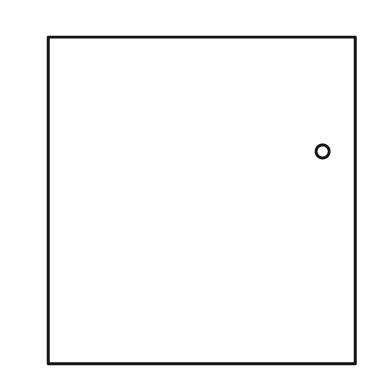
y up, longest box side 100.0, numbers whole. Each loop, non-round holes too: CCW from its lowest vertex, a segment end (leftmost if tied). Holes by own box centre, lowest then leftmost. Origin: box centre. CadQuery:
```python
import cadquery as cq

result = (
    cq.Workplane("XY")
    .moveTo(-47.0, -50.0)
    .lineTo(47.0, -50.0)
    .lineTo(47.0, 50.0)
    .lineTo(-47.0, 50.0)
    .close()
    .moveTo(37.0, 15.0)
    .circle(2.0)
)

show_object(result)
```